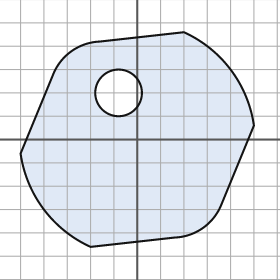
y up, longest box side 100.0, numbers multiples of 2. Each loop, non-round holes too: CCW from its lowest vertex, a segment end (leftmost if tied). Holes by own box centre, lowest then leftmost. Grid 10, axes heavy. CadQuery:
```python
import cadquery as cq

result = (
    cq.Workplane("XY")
    .moveTo(-20.0, -46.0)
    .lineTo(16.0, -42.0)
    .threePointArc((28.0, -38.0), (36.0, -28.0))
    .lineTo(50.0, 6.0)
    .threePointArc((40.0, 30.0), (20.0, 46.0))
    .lineTo(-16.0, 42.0)
    .threePointArc((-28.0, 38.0), (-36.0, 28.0))
    .lineTo(-50.0, -6.0)
    .threePointArc((-40.0, -30.0), (-20.0, -46.0))
    .close()
    .moveTo(-8.0, 20.0)
    .circle(10.0)
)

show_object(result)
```